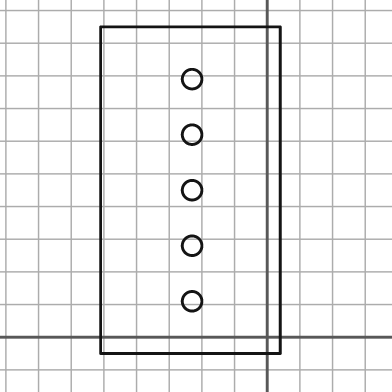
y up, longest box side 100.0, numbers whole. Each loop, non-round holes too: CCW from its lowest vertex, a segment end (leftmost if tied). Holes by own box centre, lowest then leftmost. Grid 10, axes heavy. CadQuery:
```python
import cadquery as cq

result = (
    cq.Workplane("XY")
    .moveTo(-51.0, -5.0)
    .lineTo(4.0, -5.0)
    .lineTo(4.0, 95.0)
    .lineTo(-51.0, 95.0)
    .close()
    .moveTo(-23.0, 11.0)
    .circle(3.0)
    .moveTo(-23.0, 28.0)
    .circle(3.0)
    .moveTo(-23.0, 45.0)
    .circle(3.0)
    .moveTo(-23.0, 62.0)
    .circle(3.0)
    .moveTo(-23.0, 79.0)
    .circle(3.0)
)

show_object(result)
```